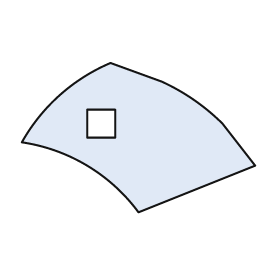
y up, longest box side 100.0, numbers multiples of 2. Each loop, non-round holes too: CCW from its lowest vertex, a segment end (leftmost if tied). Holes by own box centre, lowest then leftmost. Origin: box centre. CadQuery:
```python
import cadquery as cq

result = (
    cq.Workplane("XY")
    .moveTo(0.0, -32.0)
    .lineTo(50.0, -12.0)
    .lineTo(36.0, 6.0)
    .threePointArc((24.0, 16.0), (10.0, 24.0))
    .lineTo(-12.0, 32.0)
    .threePointArc((-34.0, 18.0), (-50.0, -2.0))
    .threePointArc((-22.0, -12.0), (0.0, -32.0))
    .close()
    .moveTo(-22.0, 0.0)
    .lineTo(-10.0, 0.0)
    .lineTo(-10.0, 12.0)
    .lineTo(-22.0, 12.0)
    .close()
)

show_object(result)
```